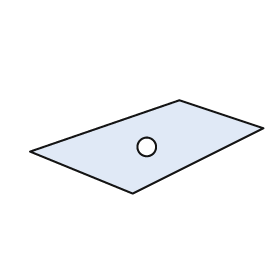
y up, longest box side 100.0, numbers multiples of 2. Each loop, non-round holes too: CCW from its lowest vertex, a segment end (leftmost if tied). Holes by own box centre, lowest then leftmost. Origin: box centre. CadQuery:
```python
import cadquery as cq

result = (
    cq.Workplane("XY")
    .moveTo(-6.0, -20.0)
    .lineTo(50.0, 8.0)
    .lineTo(14.0, 20.0)
    .lineTo(-50.0, -2.0)
    .close()
    .moveTo(0.0, 0.0)
    .circle(4.0)
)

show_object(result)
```